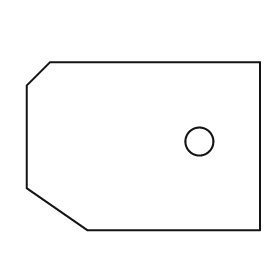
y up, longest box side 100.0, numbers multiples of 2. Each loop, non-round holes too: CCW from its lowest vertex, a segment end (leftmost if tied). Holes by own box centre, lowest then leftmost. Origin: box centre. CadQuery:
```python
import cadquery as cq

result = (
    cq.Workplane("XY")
    .moveTo(-24.0, -36.0)
    .lineTo(50.0, -36.0)
    .lineTo(50.0, 36.0)
    .lineTo(-40.0, 36.0)
    .lineTo(-50.0, 26.0)
    .lineTo(-50.0, -18.0)
    .close()
    .moveTo(24.0, 2.0)
    .circle(6.0)
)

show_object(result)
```